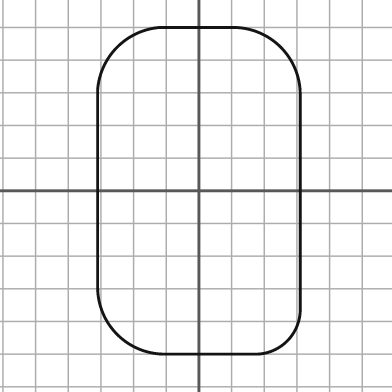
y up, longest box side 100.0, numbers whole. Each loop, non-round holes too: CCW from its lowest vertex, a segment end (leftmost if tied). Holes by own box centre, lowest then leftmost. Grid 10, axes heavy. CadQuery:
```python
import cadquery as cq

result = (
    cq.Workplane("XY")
    .moveTo(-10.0, -50.0)
    .lineTo(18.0, -50.0)
    .threePointArc((27.0, -46.0), (31.0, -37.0))
    .lineTo(31.0, 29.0)
    .threePointArc((25.0, 44.0), (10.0, 50.0))
    .lineTo(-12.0, 50.0)
    .threePointArc((-25.0, 44.0), (-31.0, 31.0))
    .lineTo(-31.0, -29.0)
    .threePointArc((-25.0, -44.0), (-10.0, -50.0))
    .close()
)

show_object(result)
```